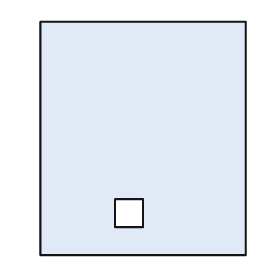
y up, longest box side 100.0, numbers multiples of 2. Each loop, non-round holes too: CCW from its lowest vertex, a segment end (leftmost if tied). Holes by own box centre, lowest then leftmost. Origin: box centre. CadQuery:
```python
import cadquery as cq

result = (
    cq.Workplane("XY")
    .moveTo(-44.0, -50.0)
    .lineTo(44.0, -50.0)
    .lineTo(44.0, 50.0)
    .lineTo(-44.0, 50.0)
    .close()
    .moveTo(-12.0, -38.0)
    .lineTo(0.0, -38.0)
    .lineTo(0.0, -26.0)
    .lineTo(-12.0, -26.0)
    .close()
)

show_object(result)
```